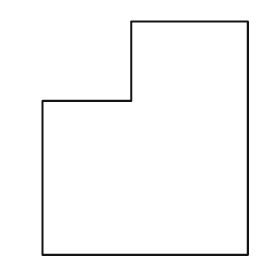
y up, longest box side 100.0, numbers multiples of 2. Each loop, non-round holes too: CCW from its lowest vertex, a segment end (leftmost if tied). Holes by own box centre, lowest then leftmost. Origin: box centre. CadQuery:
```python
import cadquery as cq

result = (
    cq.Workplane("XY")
    .moveTo(-44.0, -50.0)
    .lineTo(44.0, -50.0)
    .lineTo(44.0, 50.0)
    .lineTo(-6.0, 50.0)
    .lineTo(-6.0, 16.0)
    .lineTo(-44.0, 16.0)
    .close()
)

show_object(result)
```